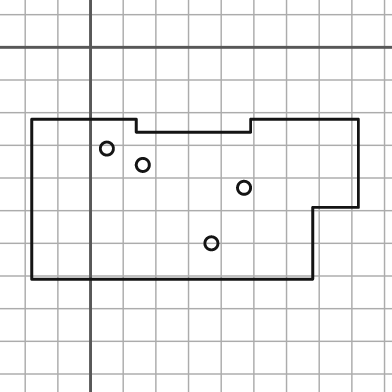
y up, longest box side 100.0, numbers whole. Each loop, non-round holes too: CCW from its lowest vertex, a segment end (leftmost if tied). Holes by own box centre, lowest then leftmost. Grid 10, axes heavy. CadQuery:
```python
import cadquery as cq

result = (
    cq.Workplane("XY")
    .moveTo(-18.0, -71.0)
    .lineTo(68.0, -71.0)
    .lineTo(68.0, -49.0)
    .lineTo(82.0, -49.0)
    .lineTo(82.0, -22.0)
    .lineTo(49.0, -22.0)
    .lineTo(49.0, -26.0)
    .lineTo(14.0, -26.0)
    .lineTo(14.0, -22.0)
    .lineTo(-18.0, -22.0)
    .close()
    .moveTo(37.0, -60.0)
    .circle(2.0)
    .moveTo(47.0, -43.0)
    .circle(2.0)
    .moveTo(16.0, -36.0)
    .circle(2.0)
    .moveTo(5.0, -31.0)
    .circle(2.0)
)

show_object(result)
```